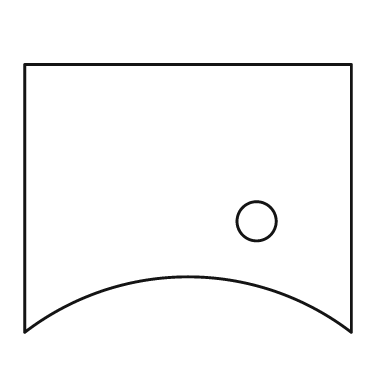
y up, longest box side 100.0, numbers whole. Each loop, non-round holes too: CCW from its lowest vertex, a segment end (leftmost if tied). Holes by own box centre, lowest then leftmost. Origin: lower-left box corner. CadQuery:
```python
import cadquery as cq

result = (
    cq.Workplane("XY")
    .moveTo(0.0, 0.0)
    .threePointArc((50.0, 17.0), (100.0, 0.0))
    .lineTo(100.0, 82.0)
    .lineTo(0.0, 82.0)
    .close()
    .moveTo(71.0, 34.0)
    .circle(6.0)
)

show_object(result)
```